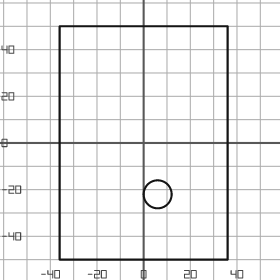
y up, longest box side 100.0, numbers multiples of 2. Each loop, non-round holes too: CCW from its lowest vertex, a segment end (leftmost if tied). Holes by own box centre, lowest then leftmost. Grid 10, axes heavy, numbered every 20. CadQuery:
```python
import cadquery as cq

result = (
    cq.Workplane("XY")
    .moveTo(-36.0, -50.0)
    .lineTo(36.0, -50.0)
    .lineTo(36.0, 50.0)
    .lineTo(-36.0, 50.0)
    .close()
    .moveTo(6.0, -22.0)
    .circle(6.0)
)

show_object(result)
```